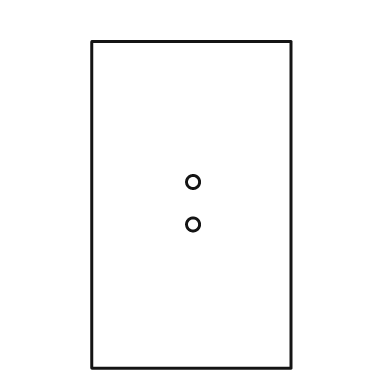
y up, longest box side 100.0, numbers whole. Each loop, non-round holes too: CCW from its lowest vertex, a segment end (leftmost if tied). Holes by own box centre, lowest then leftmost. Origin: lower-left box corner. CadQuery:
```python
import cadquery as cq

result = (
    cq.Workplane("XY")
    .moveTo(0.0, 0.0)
    .lineTo(61.0, 0.0)
    .lineTo(61.0, 100.0)
    .lineTo(0.0, 100.0)
    .close()
    .moveTo(31.0, 44.0)
    .circle(2.0)
    .moveTo(31.0, 57.0)
    .circle(2.0)
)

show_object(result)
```